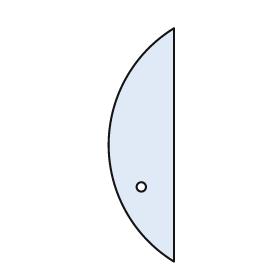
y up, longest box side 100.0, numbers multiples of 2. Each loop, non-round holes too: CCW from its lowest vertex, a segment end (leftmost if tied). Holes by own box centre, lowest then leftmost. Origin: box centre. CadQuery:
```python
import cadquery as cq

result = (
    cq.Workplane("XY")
    .moveTo(14.0, -50.0)
    .lineTo(14.0, 50.0)
    .threePointArc((-14.0, 0.0), (14.0, -50.0))
    .close()
    .moveTo(0.0, -18.0)
    .circle(2.0)
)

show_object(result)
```